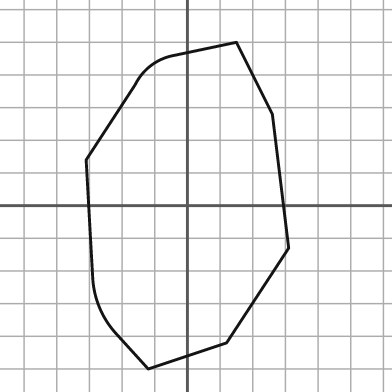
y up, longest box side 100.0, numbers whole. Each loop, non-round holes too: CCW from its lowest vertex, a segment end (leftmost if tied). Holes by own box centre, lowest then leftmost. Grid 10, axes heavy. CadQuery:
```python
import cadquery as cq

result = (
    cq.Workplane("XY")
    .moveTo(-12.0, -50.0)
    .lineTo(12.0, -42.0)
    .lineTo(31.0, -13.0)
    .lineTo(26.0, 28.0)
    .lineTo(15.0, 50.0)
    .lineTo(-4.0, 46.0)
    .threePointArc((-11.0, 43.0), (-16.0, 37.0))
    .lineTo(-31.0, 14.0)
    .lineTo(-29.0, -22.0)
    .threePointArc((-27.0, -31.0), (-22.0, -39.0))
    .close()
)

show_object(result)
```